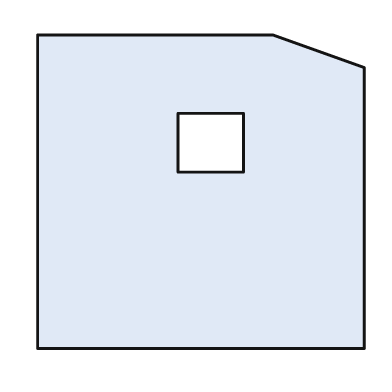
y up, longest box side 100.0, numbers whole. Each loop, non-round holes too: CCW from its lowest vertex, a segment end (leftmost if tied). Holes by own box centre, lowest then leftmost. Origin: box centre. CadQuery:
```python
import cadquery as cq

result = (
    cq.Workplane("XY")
    .moveTo(-50.0, -48.0)
    .lineTo(50.0, -48.0)
    .lineTo(50.0, 38.0)
    .lineTo(22.0, 48.0)
    .lineTo(-50.0, 48.0)
    .close()
    .moveTo(-7.0, 6.0)
    .lineTo(13.0, 6.0)
    .lineTo(13.0, 24.0)
    .lineTo(-7.0, 24.0)
    .close()
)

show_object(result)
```